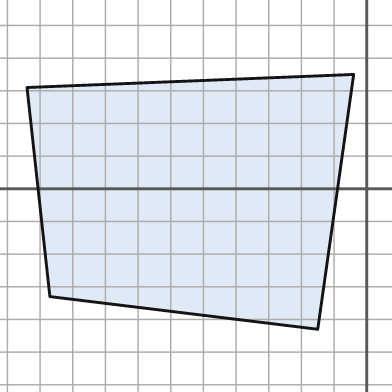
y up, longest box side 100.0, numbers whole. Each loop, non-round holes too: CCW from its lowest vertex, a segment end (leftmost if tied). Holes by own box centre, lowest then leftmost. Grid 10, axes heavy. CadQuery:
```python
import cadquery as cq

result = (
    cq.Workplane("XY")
    .moveTo(-15.0, -43.0)
    .lineTo(-4.0, 35.0)
    .lineTo(-104.0, 31.0)
    .lineTo(-97.0, -33.0)
    .close()
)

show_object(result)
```